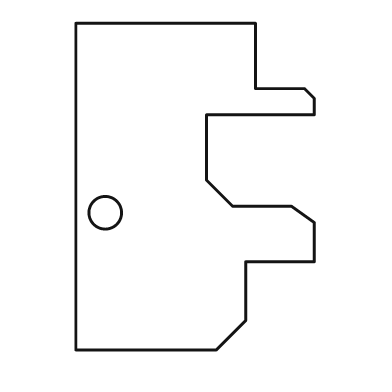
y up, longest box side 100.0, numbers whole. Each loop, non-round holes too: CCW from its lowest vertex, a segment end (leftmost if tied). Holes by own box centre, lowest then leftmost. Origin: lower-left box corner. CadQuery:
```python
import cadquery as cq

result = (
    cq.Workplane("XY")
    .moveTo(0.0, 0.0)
    .lineTo(43.0, 0.0)
    .lineTo(52.0, 9.0)
    .lineTo(52.0, 27.0)
    .lineTo(73.0, 27.0)
    .lineTo(73.0, 39.0)
    .lineTo(66.0, 44.0)
    .lineTo(48.0, 44.0)
    .lineTo(40.0, 52.0)
    .lineTo(40.0, 72.0)
    .lineTo(73.0, 72.0)
    .lineTo(73.0, 77.0)
    .lineTo(70.0, 80.0)
    .lineTo(55.0, 80.0)
    .lineTo(55.0, 100.0)
    .lineTo(0.0, 100.0)
    .close()
    .moveTo(9.0, 42.0)
    .circle(5.0)
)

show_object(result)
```